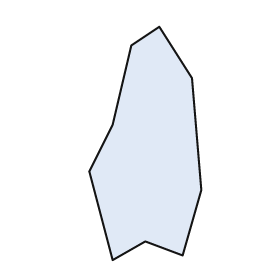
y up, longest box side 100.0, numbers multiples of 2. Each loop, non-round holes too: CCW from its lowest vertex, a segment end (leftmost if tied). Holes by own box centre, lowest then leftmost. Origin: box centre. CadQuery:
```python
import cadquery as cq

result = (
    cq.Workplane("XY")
    .moveTo(-14.0, -50.0)
    .lineTo(0.0, -42.0)
    .lineTo(16.0, -48.0)
    .lineTo(24.0, -20.0)
    .lineTo(20.0, 28.0)
    .lineTo(6.0, 50.0)
    .lineTo(-6.0, 42.0)
    .lineTo(-14.0, 8.0)
    .lineTo(-24.0, -12.0)
    .close()
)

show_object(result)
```